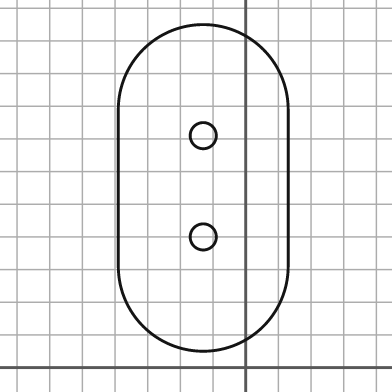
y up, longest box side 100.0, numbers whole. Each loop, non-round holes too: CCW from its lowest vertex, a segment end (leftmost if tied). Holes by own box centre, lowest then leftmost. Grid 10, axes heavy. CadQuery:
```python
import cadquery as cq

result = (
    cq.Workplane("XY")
    .moveTo(-39.0, 31.0)
    .threePointArc((-13.0, 5.0), (13.0, 31.0))
    .lineTo(13.0, 79.0)
    .threePointArc((-13.0, 105.0), (-39.0, 79.0))
    .close()
    .moveTo(-13.0, 40.0)
    .circle(4.0)
    .moveTo(-13.0, 71.0)
    .circle(4.0)
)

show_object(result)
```